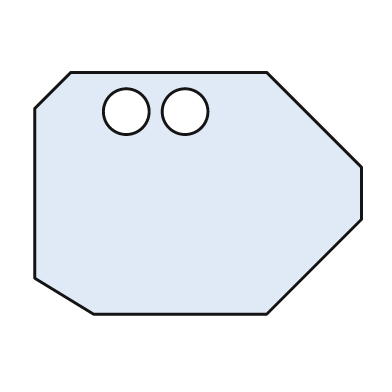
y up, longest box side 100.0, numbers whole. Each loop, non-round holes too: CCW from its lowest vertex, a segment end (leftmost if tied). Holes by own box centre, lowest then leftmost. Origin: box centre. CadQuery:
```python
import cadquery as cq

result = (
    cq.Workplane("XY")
    .moveTo(-32.0, -37.0)
    .lineTo(21.0, -37.0)
    .lineTo(50.0, -8.0)
    .lineTo(50.0, 8.0)
    .lineTo(21.0, 37.0)
    .lineTo(-39.0, 37.0)
    .lineTo(-50.0, 26.0)
    .lineTo(-50.0, -26.0)
    .close()
    .moveTo(-22.0, 25.0)
    .circle(7.0)
    .moveTo(-4.0, 25.0)
    .circle(7.0)
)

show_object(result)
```